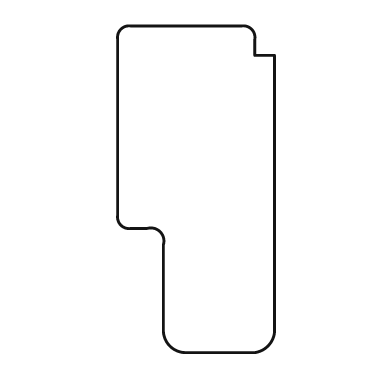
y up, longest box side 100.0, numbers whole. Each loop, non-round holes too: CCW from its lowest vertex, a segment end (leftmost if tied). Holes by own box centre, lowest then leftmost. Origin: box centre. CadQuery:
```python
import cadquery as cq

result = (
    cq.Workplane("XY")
    .moveTo(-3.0, -50.0)
    .lineTo(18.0, -50.0)
    .threePointArc((22.0, -48.0), (24.0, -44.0))
    .lineTo(24.0, 41.0)
    .lineTo(18.0, 41.0)
    .lineTo(18.0, 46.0)
    .threePointArc((17.0, 49.0), (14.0, 50.0))
    .lineTo(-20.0, 50.0)
    .threePointArc((-23.0, 49.0), (-24.0, 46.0))
    .lineTo(-24.0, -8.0)
    .threePointArc((-23.0, -11.0), (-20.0, -12.0))
    .lineTo(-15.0, -12.0)
    .threePointArc((-11.0, -13.0), (-10.0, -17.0))
    .lineTo(-10.0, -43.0)
    .threePointArc((-8.0, -48.0), (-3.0, -50.0))
    .close()
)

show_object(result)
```